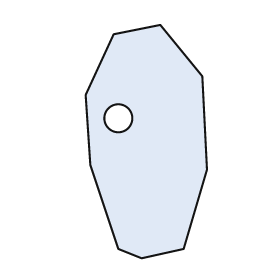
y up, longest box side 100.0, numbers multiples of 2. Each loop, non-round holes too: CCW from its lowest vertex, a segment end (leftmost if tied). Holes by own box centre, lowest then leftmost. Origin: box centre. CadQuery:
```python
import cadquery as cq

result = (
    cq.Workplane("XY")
    .moveTo(-2.0, -50.0)
    .lineTo(16.0, -46.0)
    .lineTo(26.0, -12.0)
    .lineTo(24.0, 28.0)
    .lineTo(6.0, 50.0)
    .lineTo(-14.0, 46.0)
    .lineTo(-26.0, 20.0)
    .lineTo(-24.0, -10.0)
    .lineTo(-12.0, -46.0)
    .close()
    .moveTo(-12.0, 10.0)
    .circle(6.0)
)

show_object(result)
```